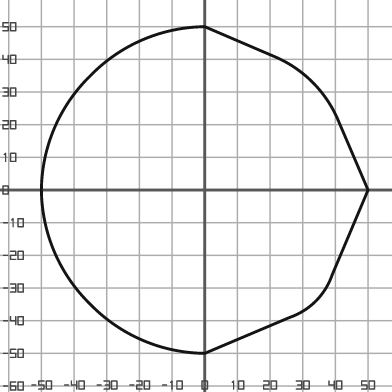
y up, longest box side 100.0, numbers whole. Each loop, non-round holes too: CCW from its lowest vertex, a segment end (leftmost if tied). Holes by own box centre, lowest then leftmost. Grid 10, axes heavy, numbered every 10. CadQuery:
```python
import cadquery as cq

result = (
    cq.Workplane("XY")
    .moveTo(0.0, -50.0)
    .lineTo(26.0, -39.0)
    .threePointArc((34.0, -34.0), (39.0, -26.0))
    .lineTo(50.0, 0.0)
    .lineTo(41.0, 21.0)
    .threePointArc((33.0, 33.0), (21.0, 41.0))
    .lineTo(0.0, 50.0)
    .threePointArc((-19.0, 46.0), (-35.0, 35.0))
    .threePointArc((-46.0, 19.0), (-50.0, 0.0))
    .threePointArc((-46.0, -19.0), (-35.0, -35.0))
    .threePointArc((-19.0, -46.0), (0.0, -50.0))
    .close()
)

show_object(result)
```